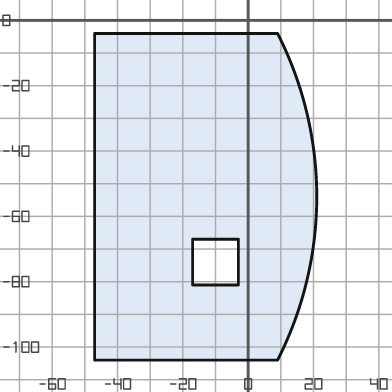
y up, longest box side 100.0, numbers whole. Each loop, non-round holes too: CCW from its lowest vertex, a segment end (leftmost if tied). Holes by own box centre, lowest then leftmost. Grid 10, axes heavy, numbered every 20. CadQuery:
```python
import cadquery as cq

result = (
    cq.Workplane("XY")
    .moveTo(-47.0, -104.0)
    .lineTo(9.0, -104.0)
    .threePointArc((21.0, -54.0), (9.0, -4.0))
    .lineTo(-47.0, -4.0)
    .close()
    .moveTo(-17.0, -81.0)
    .lineTo(-3.0, -81.0)
    .lineTo(-3.0, -67.0)
    .lineTo(-17.0, -67.0)
    .close()
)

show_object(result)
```